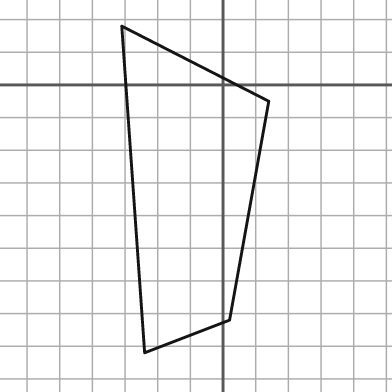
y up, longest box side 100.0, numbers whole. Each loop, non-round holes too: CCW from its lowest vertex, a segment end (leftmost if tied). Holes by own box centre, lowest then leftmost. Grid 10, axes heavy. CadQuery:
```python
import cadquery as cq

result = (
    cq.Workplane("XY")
    .moveTo(-24.0, -82.0)
    .lineTo(2.0, -72.0)
    .lineTo(14.0, -5.0)
    .lineTo(-31.0, 18.0)
    .close()
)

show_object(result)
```